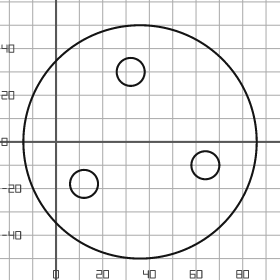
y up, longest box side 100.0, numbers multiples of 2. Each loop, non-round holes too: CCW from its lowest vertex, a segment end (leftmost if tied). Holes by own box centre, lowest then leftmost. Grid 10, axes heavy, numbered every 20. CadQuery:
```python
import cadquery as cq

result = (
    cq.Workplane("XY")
    .moveTo(36.0, 0.0)
    .circle(50.0)
    .moveTo(12.0, -18.0)
    .circle(6.0)
    .moveTo(64.0, -10.0)
    .circle(6.0)
    .moveTo(32.0, 30.0)
    .circle(6.0)
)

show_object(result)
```